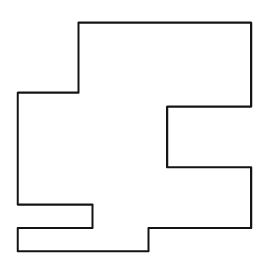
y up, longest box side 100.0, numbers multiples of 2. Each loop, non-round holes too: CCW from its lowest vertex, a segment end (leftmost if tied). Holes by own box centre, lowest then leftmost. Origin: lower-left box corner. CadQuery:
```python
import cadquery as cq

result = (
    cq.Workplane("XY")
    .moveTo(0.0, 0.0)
    .lineTo(56.0, 0.0)
    .lineTo(56.0, 10.0)
    .lineTo(100.0, 10.0)
    .lineTo(100.0, 36.0)
    .lineTo(64.0, 36.0)
    .lineTo(64.0, 62.0)
    .lineTo(100.0, 62.0)
    .lineTo(100.0, 98.0)
    .lineTo(26.0, 98.0)
    .lineTo(26.0, 68.0)
    .lineTo(0.0, 68.0)
    .lineTo(0.0, 20.0)
    .lineTo(32.0, 20.0)
    .lineTo(32.0, 10.0)
    .lineTo(0.0, 10.0)
    .close()
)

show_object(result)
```